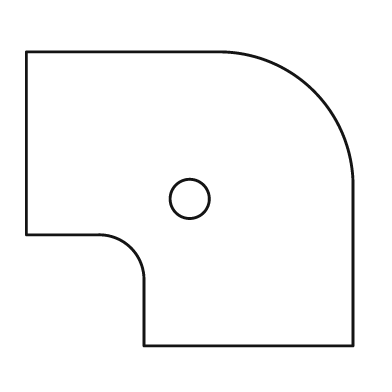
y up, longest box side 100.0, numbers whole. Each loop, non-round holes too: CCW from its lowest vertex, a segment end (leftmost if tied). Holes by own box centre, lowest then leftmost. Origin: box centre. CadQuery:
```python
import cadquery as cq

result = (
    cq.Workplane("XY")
    .moveTo(-14.0, -45.0)
    .lineTo(50.0, -45.0)
    .lineTo(50.0, 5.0)
    .threePointArc((38.0, 33.0), (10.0, 45.0))
    .lineTo(-50.0, 45.0)
    .lineTo(-50.0, -11.0)
    .lineTo(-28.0, -11.0)
    .threePointArc((-18.0, -15.0), (-14.0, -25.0))
    .close()
    .moveTo(0.0, 0.0)
    .circle(6.0)
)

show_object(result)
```